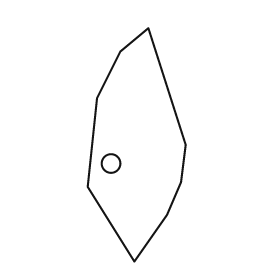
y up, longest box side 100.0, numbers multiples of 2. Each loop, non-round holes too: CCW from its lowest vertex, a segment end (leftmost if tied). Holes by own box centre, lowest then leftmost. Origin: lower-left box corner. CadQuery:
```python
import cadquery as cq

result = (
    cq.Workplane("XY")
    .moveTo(20.0, 0.0)
    .lineTo(34.0, 20.0)
    .lineTo(40.0, 34.0)
    .lineTo(42.0, 50.0)
    .lineTo(26.0, 100.0)
    .lineTo(14.0, 90.0)
    .lineTo(4.0, 70.0)
    .lineTo(0.0, 32.0)
    .close()
    .moveTo(10.0, 42.0)
    .circle(4.0)
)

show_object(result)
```